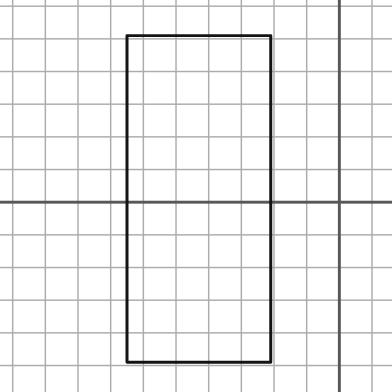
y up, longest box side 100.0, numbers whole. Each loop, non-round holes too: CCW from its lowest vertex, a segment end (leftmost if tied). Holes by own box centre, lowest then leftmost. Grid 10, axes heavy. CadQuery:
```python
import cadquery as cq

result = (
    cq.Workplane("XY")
    .moveTo(-65.0, -49.0)
    .lineTo(-21.0, -49.0)
    .lineTo(-21.0, 51.0)
    .lineTo(-65.0, 51.0)
    .close()
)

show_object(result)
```